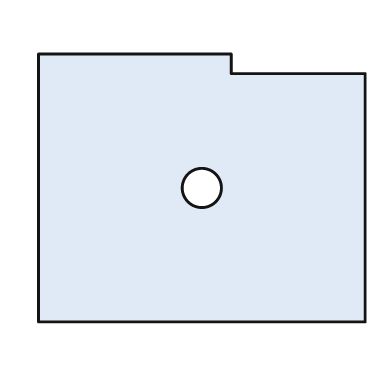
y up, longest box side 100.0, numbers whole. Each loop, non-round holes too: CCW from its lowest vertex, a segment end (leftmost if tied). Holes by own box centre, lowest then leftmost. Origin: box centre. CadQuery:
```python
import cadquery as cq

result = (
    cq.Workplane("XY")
    .moveTo(-50.0, -41.0)
    .lineTo(50.0, -41.0)
    .lineTo(50.0, 35.0)
    .lineTo(9.0, 35.0)
    .lineTo(9.0, 41.0)
    .lineTo(-50.0, 41.0)
    .close()
    .moveTo(0.0, 0.0)
    .circle(6.0)
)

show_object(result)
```